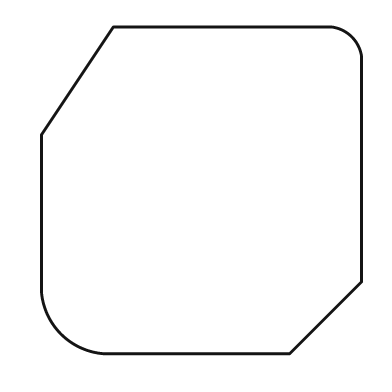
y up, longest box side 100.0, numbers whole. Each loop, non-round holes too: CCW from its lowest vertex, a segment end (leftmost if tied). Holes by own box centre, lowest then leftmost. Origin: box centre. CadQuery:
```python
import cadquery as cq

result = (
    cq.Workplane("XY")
    .moveTo(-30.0, -50.0)
    .lineTo(27.0, -50.0)
    .lineTo(49.0, -28.0)
    .lineTo(49.0, 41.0)
    .threePointArc((46.0, 47.0), (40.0, 50.0))
    .lineTo(-27.0, 50.0)
    .lineTo(-49.0, 17.0)
    .lineTo(-49.0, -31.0)
    .threePointArc((-43.0, -44.0), (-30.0, -50.0))
    .close()
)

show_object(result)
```